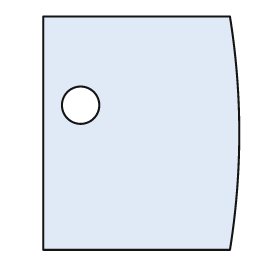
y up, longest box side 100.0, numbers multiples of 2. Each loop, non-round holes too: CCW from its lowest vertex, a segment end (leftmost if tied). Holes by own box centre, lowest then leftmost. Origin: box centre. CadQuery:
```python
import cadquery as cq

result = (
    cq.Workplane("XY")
    .moveTo(-42.0, -50.0)
    .lineTo(38.0, -50.0)
    .threePointArc((42.0, 0.0), (38.0, 50.0))
    .lineTo(-42.0, 50.0)
    .close()
    .moveTo(-26.0, 12.0)
    .circle(8.0)
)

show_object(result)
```